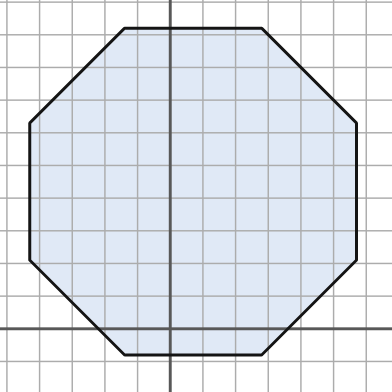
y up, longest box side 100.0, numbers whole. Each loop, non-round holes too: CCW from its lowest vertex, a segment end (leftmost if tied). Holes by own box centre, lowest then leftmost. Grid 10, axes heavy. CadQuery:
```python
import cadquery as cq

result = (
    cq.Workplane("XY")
    .moveTo(-14.0, -8.0)
    .lineTo(28.0, -8.0)
    .lineTo(57.0, 21.0)
    .lineTo(57.0, 63.0)
    .lineTo(28.0, 92.0)
    .lineTo(-14.0, 92.0)
    .lineTo(-43.0, 63.0)
    .lineTo(-43.0, 21.0)
    .close()
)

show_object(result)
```